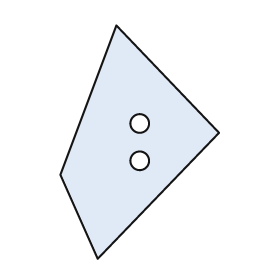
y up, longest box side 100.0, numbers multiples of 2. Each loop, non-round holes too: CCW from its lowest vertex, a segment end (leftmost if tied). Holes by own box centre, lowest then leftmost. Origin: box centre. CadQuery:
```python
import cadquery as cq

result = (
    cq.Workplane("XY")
    .moveTo(-18.0, -50.0)
    .lineTo(34.0, 4.0)
    .lineTo(-10.0, 50.0)
    .lineTo(-34.0, -14.0)
    .close()
    .moveTo(0.0, -8.0)
    .circle(4.0)
    .moveTo(0.0, 8.0)
    .circle(4.0)
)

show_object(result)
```